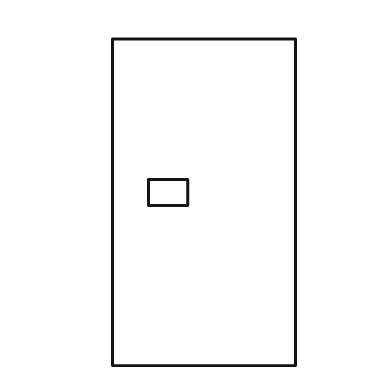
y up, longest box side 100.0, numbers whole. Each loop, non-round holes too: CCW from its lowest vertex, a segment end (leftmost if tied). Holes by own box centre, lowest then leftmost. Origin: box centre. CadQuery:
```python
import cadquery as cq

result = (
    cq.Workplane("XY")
    .moveTo(-28.0, -50.0)
    .lineTo(28.0, -50.0)
    .lineTo(28.0, 50.0)
    .lineTo(-28.0, 50.0)
    .close()
    .moveTo(-17.0, -1.0)
    .lineTo(-5.0, -1.0)
    .lineTo(-5.0, 7.0)
    .lineTo(-17.0, 7.0)
    .close()
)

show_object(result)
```